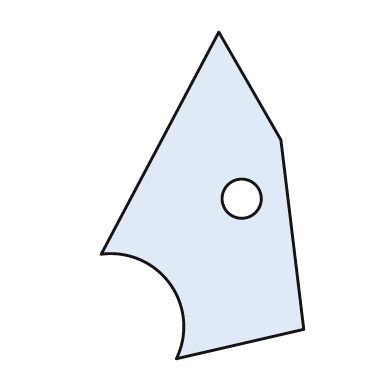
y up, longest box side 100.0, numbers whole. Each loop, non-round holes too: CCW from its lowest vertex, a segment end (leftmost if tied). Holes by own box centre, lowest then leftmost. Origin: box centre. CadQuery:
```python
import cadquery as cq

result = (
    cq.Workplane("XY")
    .moveTo(-8.0, -50.0)
    .lineTo(31.0, -41.0)
    .lineTo(24.0, 17.0)
    .lineTo(5.0, 50.0)
    .lineTo(-31.0, -18.0)
    .threePointArc((-10.0, -27.0), (-8.0, -50.0))
    .close()
    .moveTo(12.0, -1.0)
    .circle(6.0)
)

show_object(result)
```